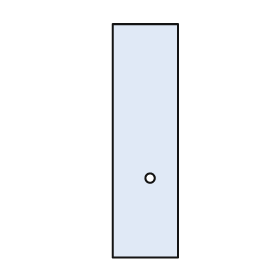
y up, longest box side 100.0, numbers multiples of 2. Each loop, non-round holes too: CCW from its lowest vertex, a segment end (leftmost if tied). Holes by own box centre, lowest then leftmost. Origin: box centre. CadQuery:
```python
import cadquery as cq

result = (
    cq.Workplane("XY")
    .moveTo(-14.0, -50.0)
    .lineTo(14.0, -50.0)
    .lineTo(14.0, 50.0)
    .lineTo(-14.0, 50.0)
    .close()
    .moveTo(2.0, -16.0)
    .circle(2.0)
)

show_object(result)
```